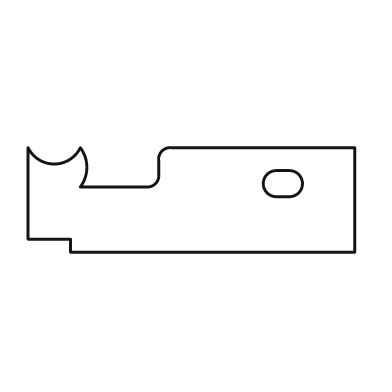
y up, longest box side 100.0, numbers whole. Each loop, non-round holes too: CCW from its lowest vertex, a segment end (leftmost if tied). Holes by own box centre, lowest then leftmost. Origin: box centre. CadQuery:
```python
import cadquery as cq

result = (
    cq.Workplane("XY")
    .moveTo(-37.0, -16.0)
    .lineTo(50.0, -16.0)
    .lineTo(50.0, 16.0)
    .lineTo(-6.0, 16.0)
    .threePointArc((-9.0, 15.0), (-10.0, 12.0))
    .lineTo(-10.0, 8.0)
    .threePointArc((-11.0, 5.0), (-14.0, 4.0))
    .lineTo(-34.0, 4.0)
    .threePointArc((-32.0, 10.0), (-34.0, 16.0))
    .threePointArc((-42.0, 11.0), (-50.0, 16.0))
    .lineTo(-50.0, -12.0)
    .lineTo(-37.0, -12.0)
    .close()
    .moveTo(26.0, 1.0)
    .lineTo(30.0, 1.0)
    .threePointArc((34.0, 5.0), (30.0, 9.0))
    .lineTo(26.0, 9.0)
    .threePointArc((22.0, 5.0), (26.0, 1.0))
    .close()
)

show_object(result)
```